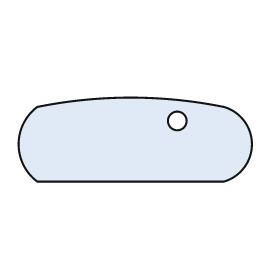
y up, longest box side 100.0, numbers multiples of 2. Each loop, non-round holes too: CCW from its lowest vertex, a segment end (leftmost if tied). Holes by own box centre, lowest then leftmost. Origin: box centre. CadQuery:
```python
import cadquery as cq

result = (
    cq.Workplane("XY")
    .moveTo(-42.0, -18.0)
    .lineTo(38.0, -18.0)
    .threePointArc((50.0, -2.0), (38.0, 14.0))
    .threePointArc((-2.0, 18.0), (-42.0, 14.0))
    .threePointArc((-50.0, -2.0), (-42.0, -18.0))
    .close()
    .moveTo(18.0, 8.0)
    .circle(4.0)
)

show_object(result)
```